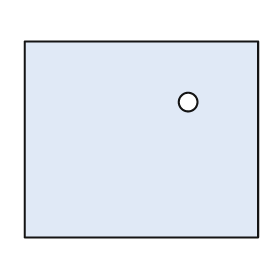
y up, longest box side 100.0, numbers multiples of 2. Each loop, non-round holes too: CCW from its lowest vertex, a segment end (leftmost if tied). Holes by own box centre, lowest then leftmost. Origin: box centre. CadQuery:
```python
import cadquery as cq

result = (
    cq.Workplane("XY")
    .moveTo(-50.0, -42.0)
    .lineTo(50.0, -42.0)
    .lineTo(50.0, 42.0)
    .lineTo(-50.0, 42.0)
    .close()
    .moveTo(20.0, 16.0)
    .circle(4.0)
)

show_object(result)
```